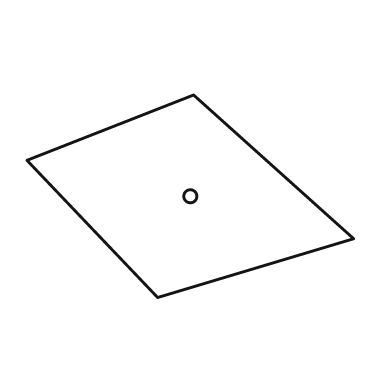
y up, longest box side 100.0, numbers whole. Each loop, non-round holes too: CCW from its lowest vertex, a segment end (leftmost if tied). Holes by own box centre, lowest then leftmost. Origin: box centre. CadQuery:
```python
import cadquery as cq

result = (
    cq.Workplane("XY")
    .moveTo(-10.0, -31.0)
    .lineTo(50.0, -13.0)
    .lineTo(1.0, 31.0)
    .lineTo(-50.0, 11.0)
    .close()
    .moveTo(0.0, 0.0)
    .circle(2.0)
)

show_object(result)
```